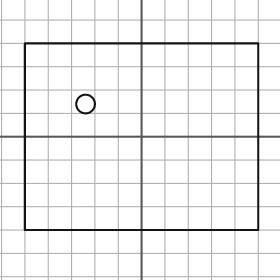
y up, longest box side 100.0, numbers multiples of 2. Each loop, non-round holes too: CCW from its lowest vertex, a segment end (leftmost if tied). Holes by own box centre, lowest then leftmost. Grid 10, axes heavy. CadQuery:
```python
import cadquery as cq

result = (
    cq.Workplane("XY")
    .moveTo(-50.0, -40.0)
    .lineTo(50.0, -40.0)
    .lineTo(50.0, 40.0)
    .lineTo(-50.0, 40.0)
    .close()
    .moveTo(-24.0, 14.0)
    .circle(4.0)
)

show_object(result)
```